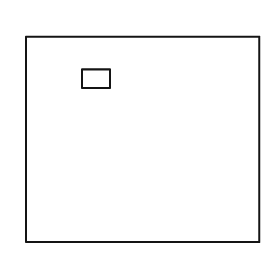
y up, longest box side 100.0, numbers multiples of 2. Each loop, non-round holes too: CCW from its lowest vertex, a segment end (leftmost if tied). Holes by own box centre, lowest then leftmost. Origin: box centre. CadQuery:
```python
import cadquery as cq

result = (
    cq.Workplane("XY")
    .moveTo(-50.0, -44.0)
    .lineTo(50.0, -44.0)
    .lineTo(50.0, 44.0)
    .lineTo(-50.0, 44.0)
    .close()
    .moveTo(-26.0, 22.0)
    .lineTo(-14.0, 22.0)
    .lineTo(-14.0, 30.0)
    .lineTo(-26.0, 30.0)
    .close()
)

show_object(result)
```